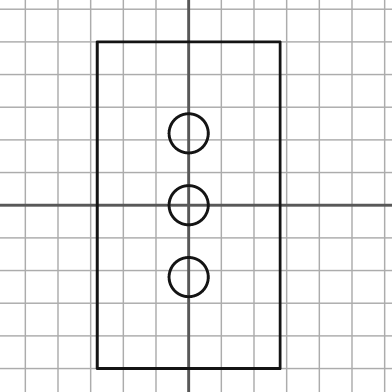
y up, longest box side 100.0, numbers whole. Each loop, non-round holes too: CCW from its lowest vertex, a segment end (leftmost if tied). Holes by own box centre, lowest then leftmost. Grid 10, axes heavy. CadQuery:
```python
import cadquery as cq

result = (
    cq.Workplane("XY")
    .moveTo(-28.0, -50.0)
    .lineTo(28.0, -50.0)
    .lineTo(28.0, 50.0)
    .lineTo(-28.0, 50.0)
    .close()
    .moveTo(0.0, -22.0)
    .circle(6.0)
    .moveTo(0.0, 0.0)
    .circle(6.0)
    .moveTo(0.0, 22.0)
    .circle(6.0)
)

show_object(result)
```